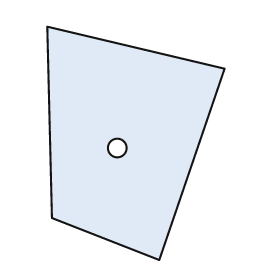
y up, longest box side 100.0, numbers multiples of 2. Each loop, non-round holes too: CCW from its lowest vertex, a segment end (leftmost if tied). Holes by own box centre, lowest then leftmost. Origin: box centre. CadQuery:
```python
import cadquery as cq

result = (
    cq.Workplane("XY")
    .moveTo(10.0, -50.0)
    .lineTo(38.0, 32.0)
    .lineTo(-38.0, 50.0)
    .lineTo(-36.0, -32.0)
    .close()
    .moveTo(-8.0, -2.0)
    .circle(4.0)
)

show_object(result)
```